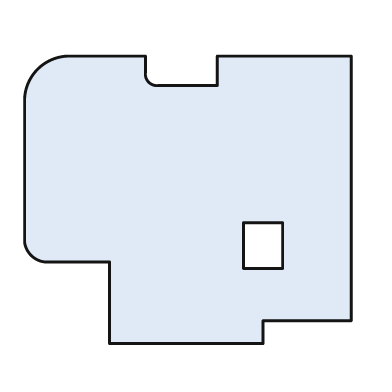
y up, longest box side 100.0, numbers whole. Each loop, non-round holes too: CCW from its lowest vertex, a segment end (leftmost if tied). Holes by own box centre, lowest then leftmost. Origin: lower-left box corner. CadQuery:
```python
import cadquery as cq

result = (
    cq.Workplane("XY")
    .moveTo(26.0, 0.0)
    .lineTo(73.0, 0.0)
    .lineTo(73.0, 7.0)
    .lineTo(100.0, 7.0)
    .lineTo(100.0, 88.0)
    .lineTo(59.0, 88.0)
    .lineTo(59.0, 79.0)
    .lineTo(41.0, 79.0)
    .threePointArc((38.0, 80.0), (37.0, 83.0))
    .lineTo(37.0, 88.0)
    .lineTo(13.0, 88.0)
    .threePointArc((4.0, 84.0), (0.0, 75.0))
    .lineTo(0.0, 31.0)
    .threePointArc((2.0, 27.0), (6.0, 25.0))
    .lineTo(26.0, 25.0)
    .close()
    .moveTo(67.0, 23.0)
    .lineTo(79.0, 23.0)
    .lineTo(79.0, 37.0)
    .lineTo(67.0, 37.0)
    .close()
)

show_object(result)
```